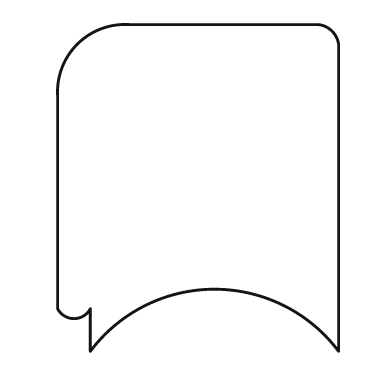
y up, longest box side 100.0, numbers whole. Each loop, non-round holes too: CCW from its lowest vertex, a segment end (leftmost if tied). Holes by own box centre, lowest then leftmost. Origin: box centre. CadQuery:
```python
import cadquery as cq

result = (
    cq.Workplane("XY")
    .moveTo(-33.0, -50.0)
    .threePointArc((5.0, -31.0), (43.0, -50.0))
    .lineTo(43.0, 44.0)
    .threePointArc((41.0, 48.0), (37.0, 50.0))
    .lineTo(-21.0, 50.0)
    .threePointArc((-37.0, 44.0), (-43.0, 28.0))
    .lineTo(-43.0, -37.0)
    .threePointArc((-38.0, -40.0), (-33.0, -37.0))
    .close()
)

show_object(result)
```